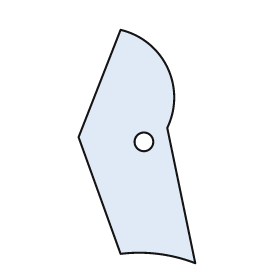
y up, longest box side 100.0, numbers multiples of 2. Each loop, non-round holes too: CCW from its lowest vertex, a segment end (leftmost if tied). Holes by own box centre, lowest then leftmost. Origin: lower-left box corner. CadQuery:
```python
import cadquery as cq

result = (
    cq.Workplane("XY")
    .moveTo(50.0, 0.0)
    .lineTo(38.0, 58.0)
    .threePointArc((38.0, 84.0), (18.0, 100.0))
    .lineTo(0.0, 54.0)
    .lineTo(18.0, 4.0)
    .threePointArc((34.0, 4.0), (50.0, 0.0))
    .close()
    .moveTo(28.0, 52.0)
    .circle(4.0)
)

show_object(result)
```